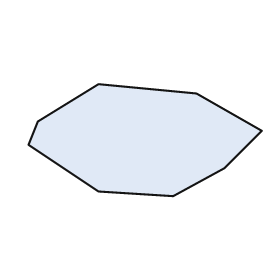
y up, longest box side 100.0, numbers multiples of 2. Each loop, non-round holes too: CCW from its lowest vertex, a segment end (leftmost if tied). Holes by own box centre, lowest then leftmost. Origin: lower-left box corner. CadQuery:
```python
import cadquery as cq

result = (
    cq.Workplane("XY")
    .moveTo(62.0, 0.0)
    .lineTo(84.0, 12.0)
    .lineTo(100.0, 28.0)
    .lineTo(72.0, 44.0)
    .lineTo(30.0, 48.0)
    .lineTo(4.0, 32.0)
    .lineTo(0.0, 22.0)
    .lineTo(30.0, 2.0)
    .close()
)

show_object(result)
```